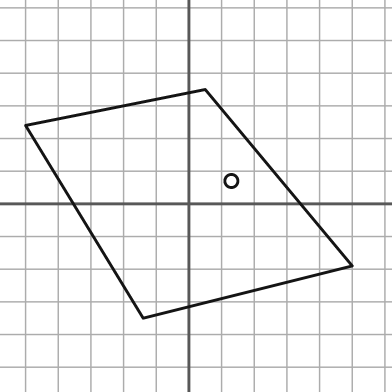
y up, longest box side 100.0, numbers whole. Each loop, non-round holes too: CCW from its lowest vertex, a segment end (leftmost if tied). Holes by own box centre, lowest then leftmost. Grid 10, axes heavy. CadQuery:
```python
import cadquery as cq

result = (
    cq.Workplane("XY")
    .moveTo(-14.0, -35.0)
    .lineTo(50.0, -19.0)
    .lineTo(5.0, 35.0)
    .lineTo(-50.0, 24.0)
    .close()
    .moveTo(13.0, 7.0)
    .circle(2.0)
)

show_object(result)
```